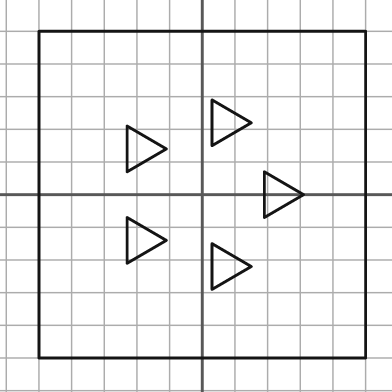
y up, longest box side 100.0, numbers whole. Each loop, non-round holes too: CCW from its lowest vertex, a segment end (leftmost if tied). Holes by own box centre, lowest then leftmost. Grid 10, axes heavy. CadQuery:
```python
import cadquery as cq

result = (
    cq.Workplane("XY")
    .moveTo(-50.0, -50.0)
    .lineTo(50.0, -50.0)
    .lineTo(50.0, 50.0)
    .lineTo(-50.0, 50.0)
    .close()
    .moveTo(3.0, -29.0)
    .lineTo(15.0, -22.0)
    .lineTo(3.0, -15.0)
    .close()
    .moveTo(-23.0, -21.0)
    .lineTo(-11.0, -14.0)
    .lineTo(-23.0, -7.0)
    .close()
    .moveTo(19.0, -7.0)
    .lineTo(31.0, 0.0)
    .lineTo(19.0, 7.0)
    .close()
    .moveTo(-23.0, 7.0)
    .lineTo(-11.0, 14.0)
    .lineTo(-23.0, 21.0)
    .close()
    .moveTo(3.0, 15.0)
    .lineTo(15.0, 22.0)
    .lineTo(3.0, 29.0)
    .close()
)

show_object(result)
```